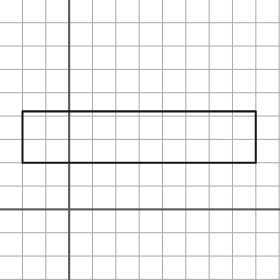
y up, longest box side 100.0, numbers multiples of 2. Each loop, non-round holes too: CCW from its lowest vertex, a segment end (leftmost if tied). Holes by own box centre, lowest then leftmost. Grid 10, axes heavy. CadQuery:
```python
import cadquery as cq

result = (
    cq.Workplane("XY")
    .moveTo(-20.0, 20.0)
    .lineTo(80.0, 20.0)
    .lineTo(80.0, 42.0)
    .lineTo(-20.0, 42.0)
    .close()
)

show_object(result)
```